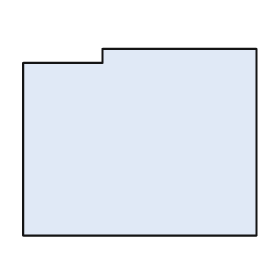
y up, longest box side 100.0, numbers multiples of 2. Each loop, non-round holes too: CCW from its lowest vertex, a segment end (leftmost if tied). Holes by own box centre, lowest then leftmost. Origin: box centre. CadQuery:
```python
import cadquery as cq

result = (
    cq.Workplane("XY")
    .moveTo(-50.0, -40.0)
    .lineTo(50.0, -40.0)
    .lineTo(50.0, 40.0)
    .lineTo(-16.0, 40.0)
    .lineTo(-16.0, 34.0)
    .lineTo(-50.0, 34.0)
    .close()
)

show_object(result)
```